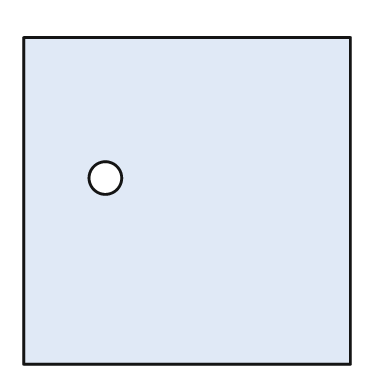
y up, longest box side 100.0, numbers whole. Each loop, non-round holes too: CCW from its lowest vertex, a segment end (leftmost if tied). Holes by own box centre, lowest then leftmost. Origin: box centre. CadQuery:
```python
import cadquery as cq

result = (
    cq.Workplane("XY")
    .moveTo(-50.0, -50.0)
    .lineTo(50.0, -50.0)
    .lineTo(50.0, 50.0)
    .lineTo(-50.0, 50.0)
    .close()
    .moveTo(-25.0, 7.0)
    .circle(5.0)
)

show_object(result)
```